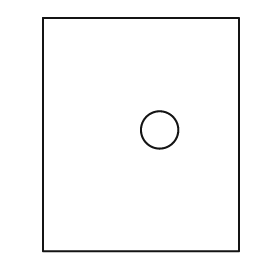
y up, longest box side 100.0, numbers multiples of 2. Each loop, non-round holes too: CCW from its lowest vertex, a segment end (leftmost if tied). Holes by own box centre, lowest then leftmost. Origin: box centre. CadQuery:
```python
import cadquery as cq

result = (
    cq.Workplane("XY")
    .moveTo(-42.0, -50.0)
    .lineTo(42.0, -50.0)
    .lineTo(42.0, 50.0)
    .lineTo(-42.0, 50.0)
    .close()
    .moveTo(8.0, 2.0)
    .circle(8.0)
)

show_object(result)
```